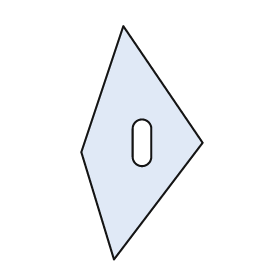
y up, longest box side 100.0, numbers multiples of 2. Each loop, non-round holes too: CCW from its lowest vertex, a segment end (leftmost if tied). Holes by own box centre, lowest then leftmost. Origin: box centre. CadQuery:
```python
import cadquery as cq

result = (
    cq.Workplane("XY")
    .moveTo(-12.0, -50.0)
    .lineTo(26.0, 0.0)
    .lineTo(-8.0, 50.0)
    .lineTo(-26.0, -4.0)
    .close()
    .moveTo(-4.0, -6.0)
    .threePointArc((0.0, -10.0), (4.0, -6.0))
    .lineTo(4.0, 6.0)
    .threePointArc((0.0, 10.0), (-4.0, 6.0))
    .close()
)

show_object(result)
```